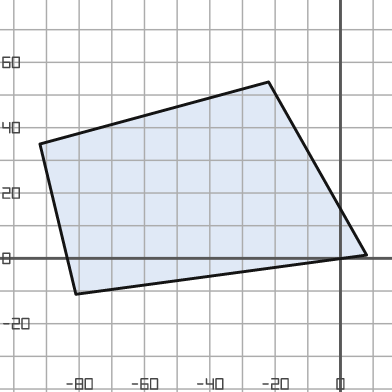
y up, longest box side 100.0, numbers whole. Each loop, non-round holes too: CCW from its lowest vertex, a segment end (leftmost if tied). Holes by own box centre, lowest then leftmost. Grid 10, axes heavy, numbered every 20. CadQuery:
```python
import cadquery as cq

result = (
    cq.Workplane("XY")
    .moveTo(-81.0, -11.0)
    .lineTo(8.0, 1.0)
    .lineTo(-22.0, 54.0)
    .lineTo(-92.0, 35.0)
    .close()
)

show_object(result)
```